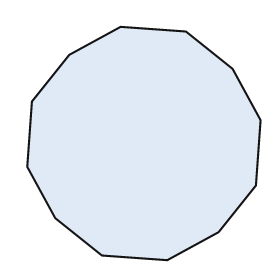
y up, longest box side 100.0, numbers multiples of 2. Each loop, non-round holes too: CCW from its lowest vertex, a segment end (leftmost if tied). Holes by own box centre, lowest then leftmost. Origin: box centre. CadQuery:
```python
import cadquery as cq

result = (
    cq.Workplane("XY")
    .moveTo(10.0, -50.0)
    .lineTo(32.0, -38.0)
    .lineTo(48.0, -18.0)
    .lineTo(50.0, 10.0)
    .lineTo(38.0, 32.0)
    .lineTo(18.0, 48.0)
    .lineTo(-10.0, 50.0)
    .lineTo(-32.0, 38.0)
    .lineTo(-48.0, 18.0)
    .lineTo(-50.0, -10.0)
    .lineTo(-38.0, -32.0)
    .lineTo(-18.0, -48.0)
    .close()
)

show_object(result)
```